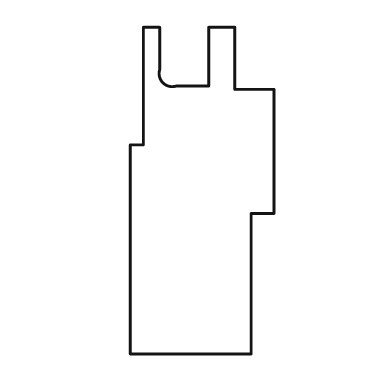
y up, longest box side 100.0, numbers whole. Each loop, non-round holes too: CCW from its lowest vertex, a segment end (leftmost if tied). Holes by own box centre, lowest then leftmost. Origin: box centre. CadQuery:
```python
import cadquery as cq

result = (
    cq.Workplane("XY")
    .moveTo(-22.0, -50.0)
    .lineTo(15.0, -50.0)
    .lineTo(15.0, -7.0)
    .lineTo(22.0, -7.0)
    .lineTo(22.0, 31.0)
    .lineTo(10.0, 31.0)
    .lineTo(10.0, 50.0)
    .lineTo(2.0, 50.0)
    .lineTo(2.0, 32.0)
    .lineTo(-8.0, 32.0)
    .threePointArc((-12.0, 33.0), (-13.0, 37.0))
    .lineTo(-13.0, 50.0)
    .lineTo(-18.0, 50.0)
    .lineTo(-18.0, 14.0)
    .lineTo(-22.0, 14.0)
    .close()
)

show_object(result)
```